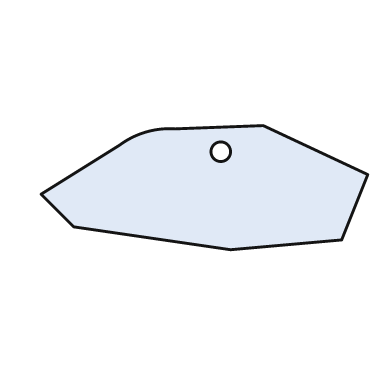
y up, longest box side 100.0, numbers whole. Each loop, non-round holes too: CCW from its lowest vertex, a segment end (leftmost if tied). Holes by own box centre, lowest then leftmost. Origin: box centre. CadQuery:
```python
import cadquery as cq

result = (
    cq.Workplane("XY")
    .moveTo(8.0, -19.0)
    .lineTo(42.0, -16.0)
    .lineTo(50.0, 4.0)
    .lineTo(18.0, 19.0)
    .lineTo(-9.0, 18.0)
    .threePointArc((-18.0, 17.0), (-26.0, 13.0))
    .lineTo(-50.0, -2.0)
    .lineTo(-40.0, -12.0)
    .close()
    .moveTo(5.0, 11.0)
    .circle(3.0)
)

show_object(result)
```